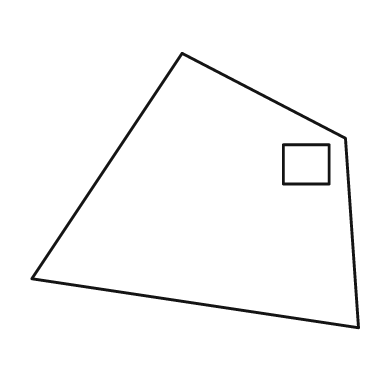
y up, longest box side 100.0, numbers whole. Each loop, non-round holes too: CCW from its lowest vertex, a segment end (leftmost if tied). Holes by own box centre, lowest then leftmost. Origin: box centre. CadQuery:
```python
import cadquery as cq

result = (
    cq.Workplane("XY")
    .moveTo(50.0, -42.0)
    .lineTo(46.0, 16.0)
    .lineTo(-4.0, 42.0)
    .lineTo(-50.0, -27.0)
    .close()
    .moveTo(27.0, 2.0)
    .lineTo(41.0, 2.0)
    .lineTo(41.0, 14.0)
    .lineTo(27.0, 14.0)
    .close()
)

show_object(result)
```